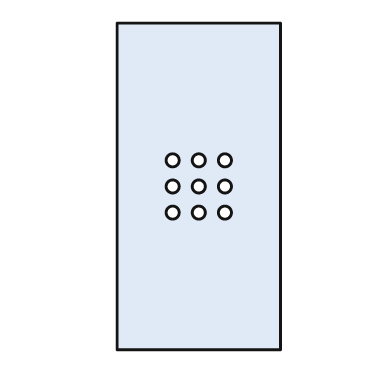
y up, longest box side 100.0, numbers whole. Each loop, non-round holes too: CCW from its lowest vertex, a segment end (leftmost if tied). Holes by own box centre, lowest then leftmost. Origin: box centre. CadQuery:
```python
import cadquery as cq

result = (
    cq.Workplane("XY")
    .moveTo(-25.0, -50.0)
    .lineTo(25.0, -50.0)
    .lineTo(25.0, 50.0)
    .lineTo(-25.0, 50.0)
    .close()
    .moveTo(-8.0, -8.0)
    .circle(2.0)
    .moveTo(0.0, -8.0)
    .circle(2.0)
    .moveTo(8.0, -8.0)
    .circle(2.0)
    .moveTo(-8.0, 0.0)
    .circle(2.0)
    .moveTo(0.0, 0.0)
    .circle(2.0)
    .moveTo(8.0, 0.0)
    .circle(2.0)
    .moveTo(-8.0, 8.0)
    .circle(2.0)
    .moveTo(0.0, 8.0)
    .circle(2.0)
    .moveTo(8.0, 8.0)
    .circle(2.0)
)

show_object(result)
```